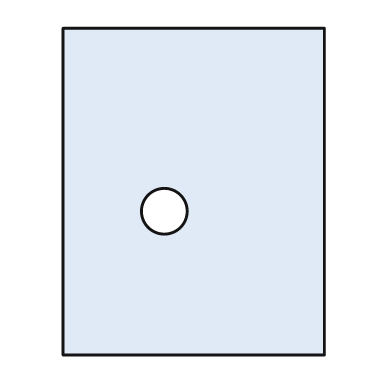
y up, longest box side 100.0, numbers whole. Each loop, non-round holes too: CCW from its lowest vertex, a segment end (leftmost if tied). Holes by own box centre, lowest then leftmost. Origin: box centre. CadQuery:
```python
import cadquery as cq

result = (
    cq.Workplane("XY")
    .moveTo(-40.0, -50.0)
    .lineTo(40.0, -50.0)
    .lineTo(40.0, 50.0)
    .lineTo(-40.0, 50.0)
    .close()
    .moveTo(-9.0, -6.0)
    .circle(7.0)
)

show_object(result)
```